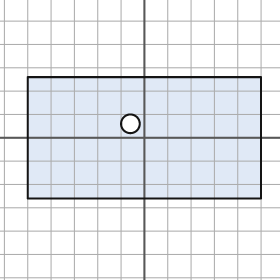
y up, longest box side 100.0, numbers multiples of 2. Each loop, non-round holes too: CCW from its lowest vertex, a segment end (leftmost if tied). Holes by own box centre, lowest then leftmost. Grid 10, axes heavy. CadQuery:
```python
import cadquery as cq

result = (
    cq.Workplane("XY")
    .moveTo(-50.0, -26.0)
    .lineTo(50.0, -26.0)
    .lineTo(50.0, 26.0)
    .lineTo(-50.0, 26.0)
    .close()
    .moveTo(-6.0, 6.0)
    .circle(4.0)
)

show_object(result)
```